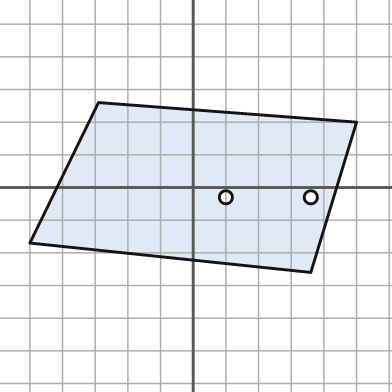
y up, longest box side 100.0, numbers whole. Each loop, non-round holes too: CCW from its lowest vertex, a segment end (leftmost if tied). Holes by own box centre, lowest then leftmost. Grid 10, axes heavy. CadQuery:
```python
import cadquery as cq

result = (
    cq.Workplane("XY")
    .moveTo(36.0, -26.0)
    .lineTo(50.0, 20.0)
    .lineTo(-29.0, 26.0)
    .lineTo(-50.0, -17.0)
    .close()
    .moveTo(10.0, -3.0)
    .circle(2.0)
    .moveTo(36.0, -3.0)
    .circle(2.0)
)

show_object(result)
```